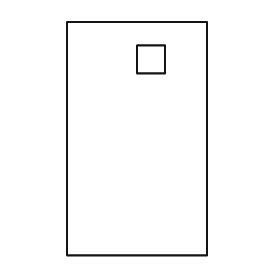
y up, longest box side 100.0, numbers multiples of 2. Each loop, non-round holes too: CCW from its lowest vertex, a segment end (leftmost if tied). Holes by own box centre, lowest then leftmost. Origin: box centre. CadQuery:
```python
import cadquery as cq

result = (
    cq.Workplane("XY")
    .moveTo(-30.0, -50.0)
    .lineTo(30.0, -50.0)
    .lineTo(30.0, 50.0)
    .lineTo(-30.0, 50.0)
    .close()
    .moveTo(0.0, 28.0)
    .lineTo(12.0, 28.0)
    .lineTo(12.0, 40.0)
    .lineTo(0.0, 40.0)
    .close()
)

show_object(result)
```